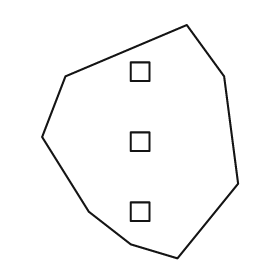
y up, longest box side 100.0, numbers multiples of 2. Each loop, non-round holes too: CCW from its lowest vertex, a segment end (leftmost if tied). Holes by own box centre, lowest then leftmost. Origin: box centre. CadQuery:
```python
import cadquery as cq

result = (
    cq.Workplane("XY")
    .moveTo(16.0, -50.0)
    .lineTo(42.0, -18.0)
    .lineTo(36.0, 28.0)
    .lineTo(20.0, 50.0)
    .lineTo(-32.0, 28.0)
    .lineTo(-42.0, 2.0)
    .lineTo(-22.0, -30.0)
    .lineTo(-4.0, -44.0)
    .close()
    .moveTo(-4.0, -34.0)
    .lineTo(4.0, -34.0)
    .lineTo(4.0, -26.0)
    .lineTo(-4.0, -26.0)
    .close()
    .moveTo(-4.0, -4.0)
    .lineTo(4.0, -4.0)
    .lineTo(4.0, 4.0)
    .lineTo(-4.0, 4.0)
    .close()
    .moveTo(-4.0, 26.0)
    .lineTo(4.0, 26.0)
    .lineTo(4.0, 34.0)
    .lineTo(-4.0, 34.0)
    .close()
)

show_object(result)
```